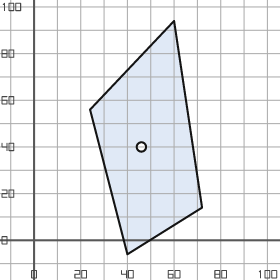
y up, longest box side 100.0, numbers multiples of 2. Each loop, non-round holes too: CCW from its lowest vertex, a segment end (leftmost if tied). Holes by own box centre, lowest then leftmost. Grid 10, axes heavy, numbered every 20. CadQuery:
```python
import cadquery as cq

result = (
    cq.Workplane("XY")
    .moveTo(40.0, -6.0)
    .lineTo(72.0, 14.0)
    .lineTo(60.0, 94.0)
    .lineTo(24.0, 56.0)
    .close()
    .moveTo(46.0, 40.0)
    .circle(2.0)
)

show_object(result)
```